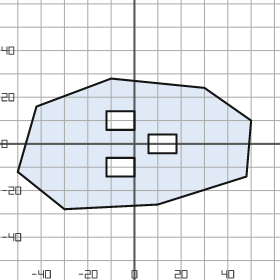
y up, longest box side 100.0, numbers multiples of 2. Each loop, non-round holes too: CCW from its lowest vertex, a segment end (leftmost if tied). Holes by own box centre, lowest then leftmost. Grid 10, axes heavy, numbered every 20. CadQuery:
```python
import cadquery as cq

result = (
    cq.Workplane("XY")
    .moveTo(-30.0, -28.0)
    .lineTo(10.0, -26.0)
    .lineTo(48.0, -14.0)
    .lineTo(50.0, 10.0)
    .lineTo(30.0, 24.0)
    .lineTo(-10.0, 28.0)
    .lineTo(-42.0, 16.0)
    .lineTo(-50.0, -12.0)
    .close()
    .moveTo(-12.0, -14.0)
    .lineTo(0.0, -14.0)
    .lineTo(0.0, -6.0)
    .lineTo(-12.0, -6.0)
    .close()
    .moveTo(6.0, -4.0)
    .lineTo(18.0, -4.0)
    .lineTo(18.0, 4.0)
    .lineTo(6.0, 4.0)
    .close()
    .moveTo(-12.0, 6.0)
    .lineTo(0.0, 6.0)
    .lineTo(0.0, 14.0)
    .lineTo(-12.0, 14.0)
    .close()
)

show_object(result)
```